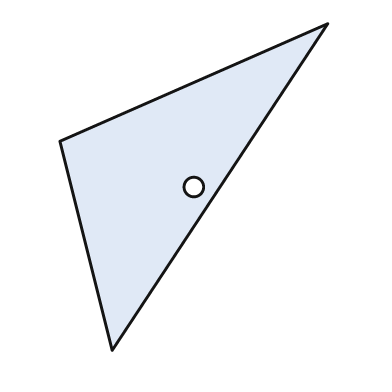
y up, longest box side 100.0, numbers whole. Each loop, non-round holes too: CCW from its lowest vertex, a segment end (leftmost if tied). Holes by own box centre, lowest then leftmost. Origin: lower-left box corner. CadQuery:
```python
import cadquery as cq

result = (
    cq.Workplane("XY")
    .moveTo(16.0, 0.0)
    .lineTo(82.0, 100.0)
    .lineTo(0.0, 64.0)
    .close()
    .moveTo(41.0, 50.0)
    .circle(3.0)
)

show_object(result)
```